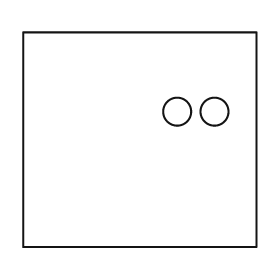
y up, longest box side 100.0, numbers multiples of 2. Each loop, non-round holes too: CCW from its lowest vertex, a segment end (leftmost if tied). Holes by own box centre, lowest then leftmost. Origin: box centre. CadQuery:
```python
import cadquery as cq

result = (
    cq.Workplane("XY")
    .moveTo(-50.0, -46.0)
    .lineTo(50.0, -46.0)
    .lineTo(50.0, 46.0)
    .lineTo(-50.0, 46.0)
    .close()
    .moveTo(16.0, 12.0)
    .circle(6.0)
    .moveTo(32.0, 12.0)
    .circle(6.0)
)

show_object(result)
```